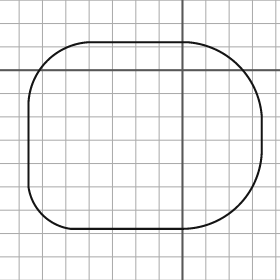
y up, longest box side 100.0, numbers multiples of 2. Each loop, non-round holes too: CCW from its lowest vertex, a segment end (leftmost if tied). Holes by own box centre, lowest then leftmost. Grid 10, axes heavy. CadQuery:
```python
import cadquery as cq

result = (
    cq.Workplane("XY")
    .moveTo(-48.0, -68.0)
    .lineTo(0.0, -68.0)
    .threePointArc((24.0, -58.0), (34.0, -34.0))
    .lineTo(34.0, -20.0)
    .threePointArc((24.0, 2.0), (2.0, 12.0))
    .lineTo(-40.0, 12.0)
    .threePointArc((-58.0, 4.0), (-66.0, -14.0))
    .lineTo(-66.0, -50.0)
    .threePointArc((-60.0, -62.0), (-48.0, -68.0))
    .close()
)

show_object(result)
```